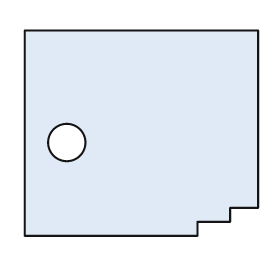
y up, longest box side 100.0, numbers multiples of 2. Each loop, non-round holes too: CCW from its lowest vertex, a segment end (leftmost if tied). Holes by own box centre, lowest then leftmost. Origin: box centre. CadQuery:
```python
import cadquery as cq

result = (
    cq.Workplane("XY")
    .moveTo(-50.0, -44.0)
    .lineTo(24.0, -44.0)
    .lineTo(24.0, -38.0)
    .lineTo(38.0, -38.0)
    .lineTo(38.0, -32.0)
    .lineTo(50.0, -32.0)
    .lineTo(50.0, 44.0)
    .lineTo(-50.0, 44.0)
    .close()
    .moveTo(-32.0, -4.0)
    .circle(8.0)
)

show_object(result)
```